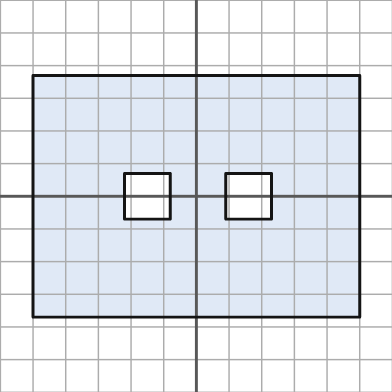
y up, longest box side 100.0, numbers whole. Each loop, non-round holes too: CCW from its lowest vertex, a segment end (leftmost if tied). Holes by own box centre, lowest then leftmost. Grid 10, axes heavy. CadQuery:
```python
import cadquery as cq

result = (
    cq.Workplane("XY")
    .moveTo(-50.0, -37.0)
    .lineTo(50.0, -37.0)
    .lineTo(50.0, 37.0)
    .lineTo(-50.0, 37.0)
    .close()
    .moveTo(-22.0, -7.0)
    .lineTo(-8.0, -7.0)
    .lineTo(-8.0, 7.0)
    .lineTo(-22.0, 7.0)
    .close()
    .moveTo(9.0, -7.0)
    .lineTo(23.0, -7.0)
    .lineTo(23.0, 7.0)
    .lineTo(9.0, 7.0)
    .close()
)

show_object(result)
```